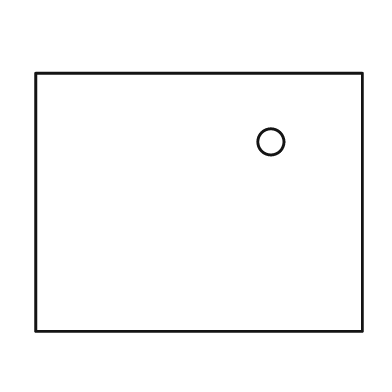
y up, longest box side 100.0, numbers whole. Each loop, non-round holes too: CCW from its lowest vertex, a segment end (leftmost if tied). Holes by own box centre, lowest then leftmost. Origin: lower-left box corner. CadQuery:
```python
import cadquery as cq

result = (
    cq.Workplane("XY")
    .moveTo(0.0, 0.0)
    .lineTo(100.0, 0.0)
    .lineTo(100.0, 79.0)
    .lineTo(0.0, 79.0)
    .close()
    .moveTo(72.0, 58.0)
    .circle(4.0)
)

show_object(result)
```